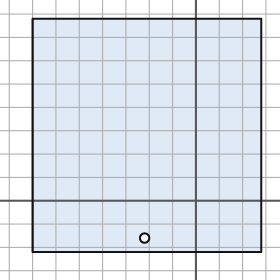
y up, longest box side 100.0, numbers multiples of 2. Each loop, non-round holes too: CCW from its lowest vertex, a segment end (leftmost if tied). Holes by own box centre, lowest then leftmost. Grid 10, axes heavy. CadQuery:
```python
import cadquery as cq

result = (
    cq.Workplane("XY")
    .moveTo(-70.0, -22.0)
    .lineTo(28.0, -22.0)
    .lineTo(28.0, 78.0)
    .lineTo(-70.0, 78.0)
    .close()
    .moveTo(-22.0, -16.0)
    .circle(2.0)
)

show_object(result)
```